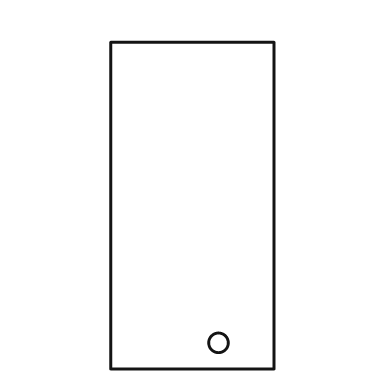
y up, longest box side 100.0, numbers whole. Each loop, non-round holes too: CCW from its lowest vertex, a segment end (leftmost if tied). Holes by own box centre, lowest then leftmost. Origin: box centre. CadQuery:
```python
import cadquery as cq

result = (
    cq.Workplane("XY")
    .moveTo(-25.0, -50.0)
    .lineTo(25.0, -50.0)
    .lineTo(25.0, 50.0)
    .lineTo(-25.0, 50.0)
    .close()
    .moveTo(8.0, -42.0)
    .circle(3.0)
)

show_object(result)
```